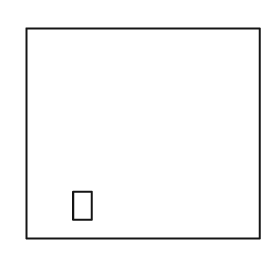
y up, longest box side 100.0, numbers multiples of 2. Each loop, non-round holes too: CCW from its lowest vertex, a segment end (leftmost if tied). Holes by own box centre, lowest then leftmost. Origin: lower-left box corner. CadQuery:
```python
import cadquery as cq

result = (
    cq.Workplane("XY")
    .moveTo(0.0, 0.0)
    .lineTo(100.0, 0.0)
    .lineTo(100.0, 90.0)
    .lineTo(0.0, 90.0)
    .close()
    .moveTo(20.0, 8.0)
    .lineTo(28.0, 8.0)
    .lineTo(28.0, 20.0)
    .lineTo(20.0, 20.0)
    .close()
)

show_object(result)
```